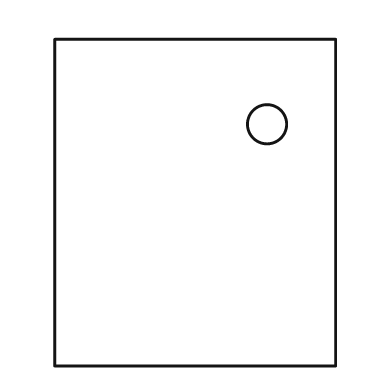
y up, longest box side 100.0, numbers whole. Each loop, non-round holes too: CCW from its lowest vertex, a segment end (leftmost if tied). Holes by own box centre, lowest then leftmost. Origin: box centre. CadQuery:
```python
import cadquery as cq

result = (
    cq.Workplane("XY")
    .moveTo(-43.0, -50.0)
    .lineTo(43.0, -50.0)
    .lineTo(43.0, 50.0)
    .lineTo(-43.0, 50.0)
    .close()
    .moveTo(22.0, 24.0)
    .circle(6.0)
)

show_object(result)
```